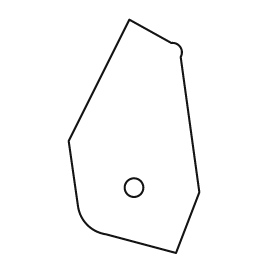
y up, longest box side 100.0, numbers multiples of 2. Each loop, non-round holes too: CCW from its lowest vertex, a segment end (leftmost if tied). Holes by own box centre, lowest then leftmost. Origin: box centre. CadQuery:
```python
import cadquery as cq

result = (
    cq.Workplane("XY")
    .moveTo(18.0, -50.0)
    .lineTo(28.0, -24.0)
    .lineTo(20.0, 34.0)
    .threePointArc((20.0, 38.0), (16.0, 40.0))
    .lineTo(-2.0, 50.0)
    .lineTo(-28.0, -2.0)
    .lineTo(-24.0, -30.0)
    .threePointArc((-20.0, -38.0), (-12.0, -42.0))
    .close()
    .moveTo(0.0, -22.0)
    .circle(4.0)
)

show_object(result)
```